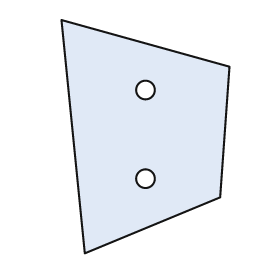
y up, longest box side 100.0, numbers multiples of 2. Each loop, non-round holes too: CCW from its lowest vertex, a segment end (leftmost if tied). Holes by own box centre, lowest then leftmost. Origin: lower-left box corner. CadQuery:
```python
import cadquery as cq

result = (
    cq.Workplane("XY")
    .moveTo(10.0, 0.0)
    .lineTo(68.0, 24.0)
    .lineTo(72.0, 80.0)
    .lineTo(0.0, 100.0)
    .close()
    .moveTo(36.0, 32.0)
    .circle(4.0)
    .moveTo(36.0, 70.0)
    .circle(4.0)
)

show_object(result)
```